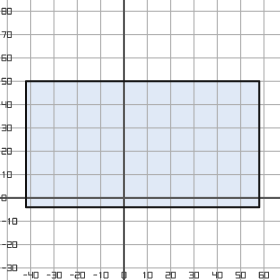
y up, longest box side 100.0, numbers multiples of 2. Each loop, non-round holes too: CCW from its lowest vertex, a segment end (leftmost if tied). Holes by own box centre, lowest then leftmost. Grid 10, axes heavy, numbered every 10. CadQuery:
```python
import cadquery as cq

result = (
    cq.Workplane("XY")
    .moveTo(-42.0, -4.0)
    .lineTo(58.0, -4.0)
    .lineTo(58.0, 50.0)
    .lineTo(-42.0, 50.0)
    .close()
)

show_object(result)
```